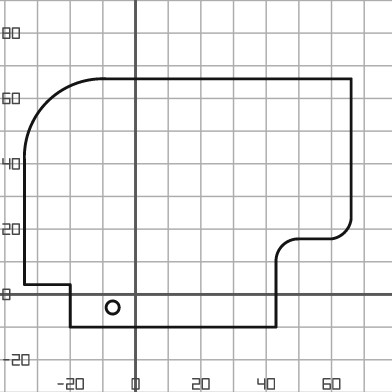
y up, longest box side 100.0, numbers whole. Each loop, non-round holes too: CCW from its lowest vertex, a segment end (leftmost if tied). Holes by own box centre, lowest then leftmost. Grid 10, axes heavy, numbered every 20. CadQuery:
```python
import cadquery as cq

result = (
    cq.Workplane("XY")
    .moveTo(-20.0, -10.0)
    .lineTo(43.0, -10.0)
    .lineTo(43.0, 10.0)
    .threePointArc((45.0, 15.0), (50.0, 17.0))
    .lineTo(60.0, 17.0)
    .threePointArc((64.0, 19.0), (66.0, 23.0))
    .lineTo(66.0, 66.0)
    .lineTo(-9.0, 66.0)
    .threePointArc((-27.0, 59.0), (-34.0, 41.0))
    .lineTo(-34.0, 3.0)
    .lineTo(-20.0, 3.0)
    .close()
    .moveTo(-7.0, -4.0)
    .circle(2.0)
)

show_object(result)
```